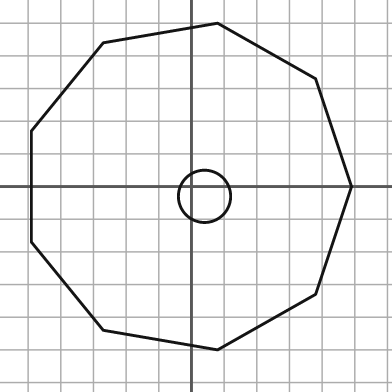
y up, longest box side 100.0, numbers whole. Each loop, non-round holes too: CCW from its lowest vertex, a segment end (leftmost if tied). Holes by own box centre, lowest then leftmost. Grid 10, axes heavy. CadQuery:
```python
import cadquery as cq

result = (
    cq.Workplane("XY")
    .moveTo(8.0, -50.0)
    .lineTo(38.0, -33.0)
    .lineTo(49.0, 0.0)
    .lineTo(38.0, 33.0)
    .lineTo(8.0, 50.0)
    .lineTo(-27.0, 44.0)
    .lineTo(-49.0, 17.0)
    .lineTo(-49.0, -17.0)
    .lineTo(-27.0, -44.0)
    .close()
    .moveTo(4.0, -3.0)
    .circle(8.0)
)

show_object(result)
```